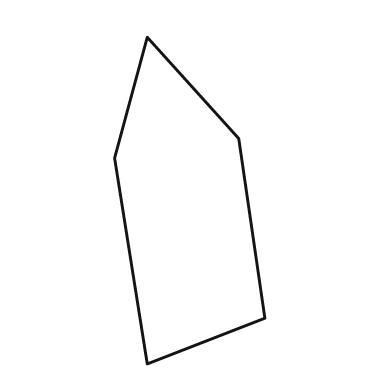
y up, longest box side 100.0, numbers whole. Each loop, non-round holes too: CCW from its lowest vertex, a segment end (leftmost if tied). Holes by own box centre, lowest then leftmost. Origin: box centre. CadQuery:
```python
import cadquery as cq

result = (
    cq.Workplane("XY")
    .moveTo(-13.0, -50.0)
    .lineTo(23.0, -36.0)
    .lineTo(15.0, 19.0)
    .lineTo(-13.0, 50.0)
    .lineTo(-23.0, 13.0)
    .close()
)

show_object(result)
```